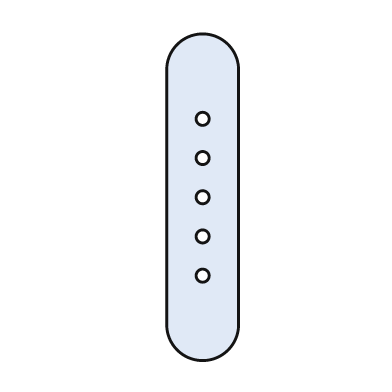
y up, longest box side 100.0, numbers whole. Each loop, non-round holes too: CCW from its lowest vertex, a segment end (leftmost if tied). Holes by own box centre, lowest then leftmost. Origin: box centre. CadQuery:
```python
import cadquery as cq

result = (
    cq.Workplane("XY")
    .moveTo(-11.0, -39.0)
    .threePointArc((0.0, -50.0), (11.0, -39.0))
    .lineTo(11.0, 39.0)
    .threePointArc((0.0, 50.0), (-11.0, 39.0))
    .close()
    .moveTo(0.0, -24.0)
    .circle(2.0)
    .moveTo(0.0, -12.0)
    .circle(2.0)
    .moveTo(0.0, 0.0)
    .circle(2.0)
    .moveTo(0.0, 12.0)
    .circle(2.0)
    .moveTo(0.0, 24.0)
    .circle(2.0)
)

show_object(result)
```